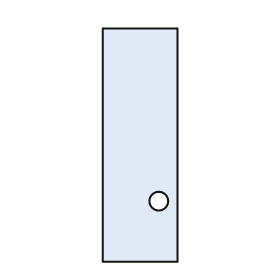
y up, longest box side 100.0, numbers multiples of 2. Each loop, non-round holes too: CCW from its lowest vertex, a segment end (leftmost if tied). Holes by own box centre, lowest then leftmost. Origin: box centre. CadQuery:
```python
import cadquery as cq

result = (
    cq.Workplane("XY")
    .moveTo(-16.0, -50.0)
    .lineTo(16.0, -50.0)
    .lineTo(16.0, 50.0)
    .lineTo(-16.0, 50.0)
    .close()
    .moveTo(8.0, -24.0)
    .circle(4.0)
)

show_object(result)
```